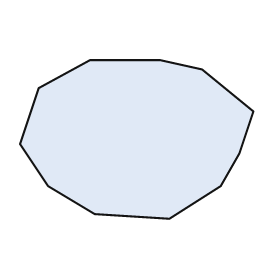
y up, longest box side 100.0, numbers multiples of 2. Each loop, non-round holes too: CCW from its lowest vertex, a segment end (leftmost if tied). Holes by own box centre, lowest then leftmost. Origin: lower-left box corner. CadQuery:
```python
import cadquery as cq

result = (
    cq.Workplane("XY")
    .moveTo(64.0, 0.0)
    .lineTo(86.0, 14.0)
    .lineTo(94.0, 28.0)
    .lineTo(100.0, 46.0)
    .lineTo(78.0, 64.0)
    .lineTo(60.0, 68.0)
    .lineTo(30.0, 68.0)
    .lineTo(8.0, 56.0)
    .lineTo(0.0, 32.0)
    .lineTo(12.0, 14.0)
    .lineTo(32.0, 2.0)
    .close()
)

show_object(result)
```